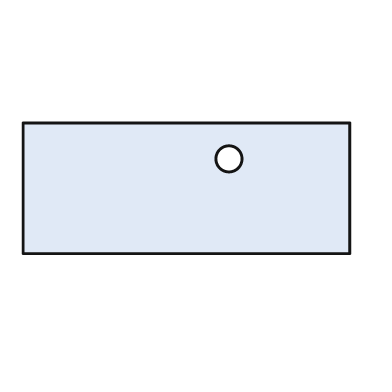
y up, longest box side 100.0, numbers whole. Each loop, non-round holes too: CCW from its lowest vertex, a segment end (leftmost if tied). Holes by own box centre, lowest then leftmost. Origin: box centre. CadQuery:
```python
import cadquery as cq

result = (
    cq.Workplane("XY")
    .moveTo(-50.0, -20.0)
    .lineTo(50.0, -20.0)
    .lineTo(50.0, 20.0)
    .lineTo(-50.0, 20.0)
    .close()
    .moveTo(13.0, 9.0)
    .circle(4.0)
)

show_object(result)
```